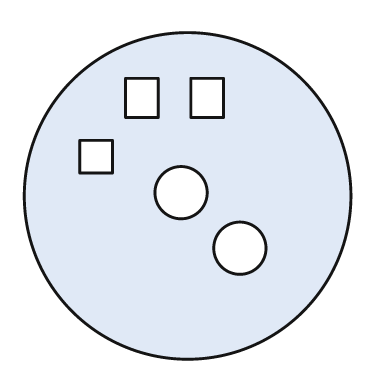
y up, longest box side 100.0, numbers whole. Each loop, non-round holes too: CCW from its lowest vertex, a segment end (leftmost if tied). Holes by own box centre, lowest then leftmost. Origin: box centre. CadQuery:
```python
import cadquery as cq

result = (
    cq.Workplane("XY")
    .moveTo(0.0, 0.0)
    .circle(50.0)
    .moveTo(16.0, -16.0)
    .circle(8.0)
    .moveTo(-2.0, 1.0)
    .circle(8.0)
    .moveTo(-33.0, 7.0)
    .lineTo(-23.0, 7.0)
    .lineTo(-23.0, 17.0)
    .lineTo(-33.0, 17.0)
    .close()
    .moveTo(-19.0, 24.0)
    .lineTo(-9.0, 24.0)
    .lineTo(-9.0, 36.0)
    .lineTo(-19.0, 36.0)
    .close()
    .moveTo(1.0, 24.0)
    .lineTo(11.0, 24.0)
    .lineTo(11.0, 36.0)
    .lineTo(1.0, 36.0)
    .close()
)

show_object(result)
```